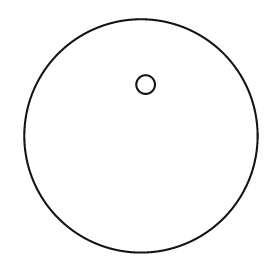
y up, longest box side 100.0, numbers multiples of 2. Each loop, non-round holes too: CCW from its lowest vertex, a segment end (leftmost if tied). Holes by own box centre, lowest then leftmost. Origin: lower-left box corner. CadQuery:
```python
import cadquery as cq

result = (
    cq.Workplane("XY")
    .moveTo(50.0, 50.0)
    .circle(50.0)
    .moveTo(52.0, 72.0)
    .circle(4.0)
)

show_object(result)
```